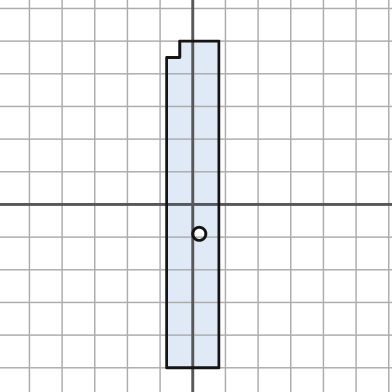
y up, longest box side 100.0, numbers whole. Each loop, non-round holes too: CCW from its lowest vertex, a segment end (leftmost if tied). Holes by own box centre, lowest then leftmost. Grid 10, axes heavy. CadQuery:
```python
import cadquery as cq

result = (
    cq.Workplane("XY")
    .moveTo(-8.0, -50.0)
    .lineTo(8.0, -50.0)
    .lineTo(8.0, 50.0)
    .lineTo(-4.0, 50.0)
    .lineTo(-4.0, 45.0)
    .lineTo(-8.0, 45.0)
    .close()
    .moveTo(2.0, -9.0)
    .circle(2.0)
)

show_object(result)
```